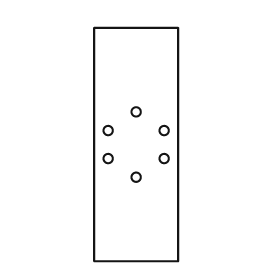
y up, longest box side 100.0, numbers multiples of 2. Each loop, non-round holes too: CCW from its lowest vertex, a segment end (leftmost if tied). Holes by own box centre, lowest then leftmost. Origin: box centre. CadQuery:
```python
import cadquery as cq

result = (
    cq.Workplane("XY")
    .moveTo(-18.0, -50.0)
    .lineTo(18.0, -50.0)
    .lineTo(18.0, 50.0)
    .lineTo(-18.0, 50.0)
    .close()
    .moveTo(0.0, -14.0)
    .circle(2.0)
    .moveTo(-12.0, -6.0)
    .circle(2.0)
    .moveTo(12.0, -6.0)
    .circle(2.0)
    .moveTo(-12.0, 6.0)
    .circle(2.0)
    .moveTo(12.0, 6.0)
    .circle(2.0)
    .moveTo(0.0, 14.0)
    .circle(2.0)
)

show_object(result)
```